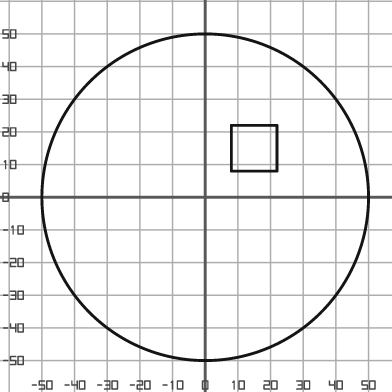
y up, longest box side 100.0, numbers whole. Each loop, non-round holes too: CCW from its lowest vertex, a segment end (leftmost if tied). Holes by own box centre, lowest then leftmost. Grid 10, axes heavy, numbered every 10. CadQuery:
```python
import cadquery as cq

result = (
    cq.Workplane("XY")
    .moveTo(0.0, 0.0)
    .circle(50.0)
    .moveTo(8.0, 8.0)
    .lineTo(22.0, 8.0)
    .lineTo(22.0, 22.0)
    .lineTo(8.0, 22.0)
    .close()
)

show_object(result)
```